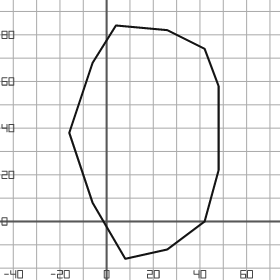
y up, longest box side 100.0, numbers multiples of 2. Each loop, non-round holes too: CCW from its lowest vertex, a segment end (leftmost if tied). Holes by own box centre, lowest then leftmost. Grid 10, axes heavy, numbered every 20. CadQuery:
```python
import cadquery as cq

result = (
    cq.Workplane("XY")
    .moveTo(8.0, -16.0)
    .lineTo(26.0, -12.0)
    .lineTo(42.0, 0.0)
    .lineTo(48.0, 22.0)
    .lineTo(48.0, 58.0)
    .lineTo(42.0, 74.0)
    .lineTo(26.0, 82.0)
    .lineTo(4.0, 84.0)
    .lineTo(-6.0, 68.0)
    .lineTo(-16.0, 38.0)
    .lineTo(-6.0, 8.0)
    .close()
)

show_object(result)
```